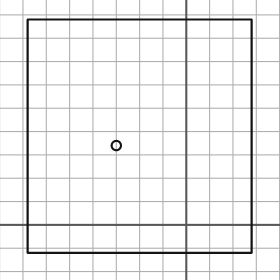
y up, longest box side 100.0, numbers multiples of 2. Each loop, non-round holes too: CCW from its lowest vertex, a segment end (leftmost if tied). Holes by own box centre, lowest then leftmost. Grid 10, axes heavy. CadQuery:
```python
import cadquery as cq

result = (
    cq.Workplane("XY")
    .moveTo(-68.0, -12.0)
    .lineTo(28.0, -12.0)
    .lineTo(28.0, 88.0)
    .lineTo(-68.0, 88.0)
    .close()
    .moveTo(-30.0, 34.0)
    .circle(2.0)
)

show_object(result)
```